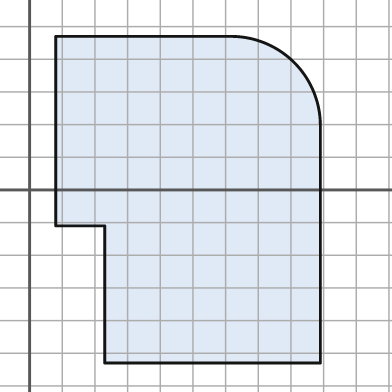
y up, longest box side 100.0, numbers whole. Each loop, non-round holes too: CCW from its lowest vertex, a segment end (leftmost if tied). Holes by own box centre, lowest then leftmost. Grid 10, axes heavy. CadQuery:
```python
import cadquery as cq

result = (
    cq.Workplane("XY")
    .moveTo(23.0, -53.0)
    .lineTo(89.0, -53.0)
    .lineTo(89.0, 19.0)
    .threePointArc((81.0, 39.0), (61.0, 47.0))
    .lineTo(8.0, 47.0)
    .lineTo(8.0, -11.0)
    .lineTo(23.0, -11.0)
    .close()
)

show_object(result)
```